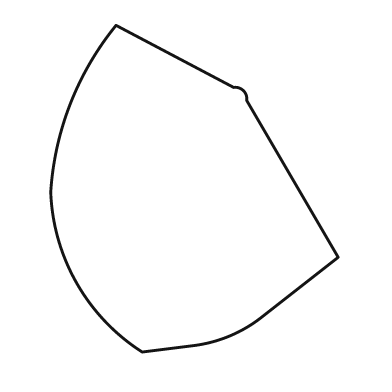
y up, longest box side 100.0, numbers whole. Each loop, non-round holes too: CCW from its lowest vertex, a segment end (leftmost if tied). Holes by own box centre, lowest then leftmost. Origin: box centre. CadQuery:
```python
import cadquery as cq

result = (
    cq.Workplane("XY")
    .moveTo(-16.0, -50.0)
    .lineTo(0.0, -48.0)
    .threePointArc((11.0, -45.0), (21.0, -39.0))
    .lineTo(44.0, -21.0)
    .lineTo(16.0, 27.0)
    .threePointArc((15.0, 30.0), (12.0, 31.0))
    .lineTo(-24.0, 50.0)
    .threePointArc((-38.0, 26.0), (-44.0, -1.0))
    .threePointArc((-36.0, -29.0), (-16.0, -50.0))
    .close()
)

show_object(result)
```